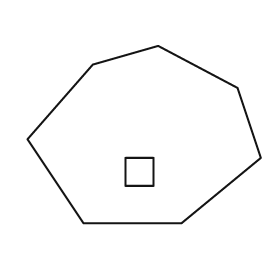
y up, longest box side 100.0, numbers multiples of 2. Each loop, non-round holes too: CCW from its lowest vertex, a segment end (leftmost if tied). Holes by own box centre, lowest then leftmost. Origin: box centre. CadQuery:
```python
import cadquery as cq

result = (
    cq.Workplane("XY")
    .moveTo(-26.0, -38.0)
    .lineTo(16.0, -38.0)
    .lineTo(50.0, -10.0)
    .lineTo(40.0, 20.0)
    .lineTo(6.0, 38.0)
    .lineTo(-22.0, 30.0)
    .lineTo(-50.0, -2.0)
    .close()
    .moveTo(-8.0, -22.0)
    .lineTo(4.0, -22.0)
    .lineTo(4.0, -10.0)
    .lineTo(-8.0, -10.0)
    .close()
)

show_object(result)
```